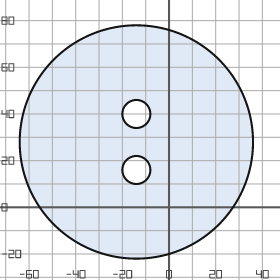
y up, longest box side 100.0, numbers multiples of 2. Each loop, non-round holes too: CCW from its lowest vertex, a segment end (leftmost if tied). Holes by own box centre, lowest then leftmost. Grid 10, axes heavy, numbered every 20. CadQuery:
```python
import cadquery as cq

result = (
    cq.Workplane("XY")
    .moveTo(-14.0, 28.0)
    .circle(50.0)
    .moveTo(-14.0, 16.0)
    .circle(6.0)
    .moveTo(-14.0, 40.0)
    .circle(6.0)
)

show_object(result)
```